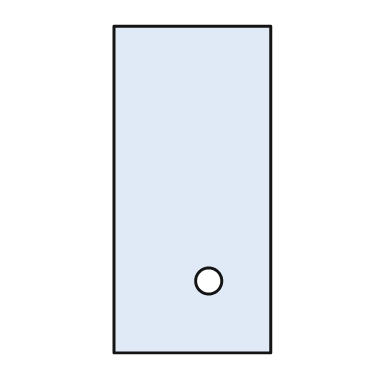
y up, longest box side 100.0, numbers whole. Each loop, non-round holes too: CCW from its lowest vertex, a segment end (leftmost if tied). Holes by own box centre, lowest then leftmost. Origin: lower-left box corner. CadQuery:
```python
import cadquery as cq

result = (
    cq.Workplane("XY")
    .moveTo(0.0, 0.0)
    .lineTo(48.0, 0.0)
    .lineTo(48.0, 100.0)
    .lineTo(0.0, 100.0)
    .close()
    .moveTo(29.0, 22.0)
    .circle(4.0)
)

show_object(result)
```